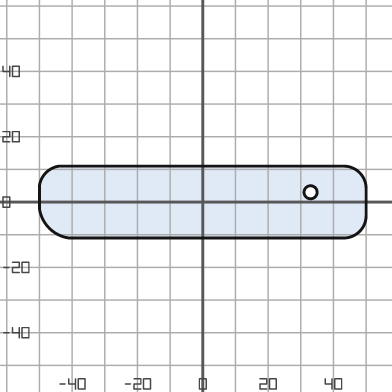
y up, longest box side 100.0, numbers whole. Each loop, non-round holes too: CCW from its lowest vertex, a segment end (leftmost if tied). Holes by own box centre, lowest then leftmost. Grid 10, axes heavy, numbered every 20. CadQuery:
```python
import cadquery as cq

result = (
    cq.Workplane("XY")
    .moveTo(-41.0, -11.0)
    .lineTo(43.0, -11.0)
    .threePointArc((48.0, -9.0), (50.0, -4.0))
    .lineTo(50.0, 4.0)
    .threePointArc((48.0, 9.0), (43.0, 11.0))
    .lineTo(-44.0, 11.0)
    .threePointArc((-48.0, 9.0), (-50.0, 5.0))
    .lineTo(-50.0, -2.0)
    .threePointArc((-47.0, -8.0), (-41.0, -11.0))
    .close()
    .moveTo(33.0, 3.0)
    .circle(2.0)
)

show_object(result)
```